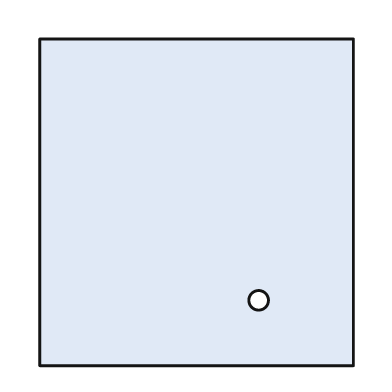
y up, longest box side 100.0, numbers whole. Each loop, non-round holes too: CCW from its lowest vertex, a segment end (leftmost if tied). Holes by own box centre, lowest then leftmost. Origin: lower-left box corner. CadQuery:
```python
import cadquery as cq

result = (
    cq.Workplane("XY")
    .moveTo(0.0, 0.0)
    .lineTo(96.0, 0.0)
    .lineTo(96.0, 100.0)
    .lineTo(0.0, 100.0)
    .close()
    .moveTo(67.0, 20.0)
    .circle(3.0)
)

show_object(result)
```